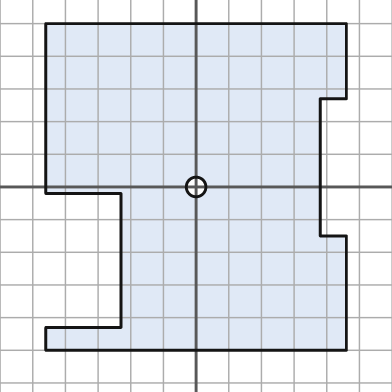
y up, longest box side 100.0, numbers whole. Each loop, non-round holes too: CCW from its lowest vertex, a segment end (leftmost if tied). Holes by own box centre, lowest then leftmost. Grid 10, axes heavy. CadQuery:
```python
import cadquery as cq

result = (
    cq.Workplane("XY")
    .moveTo(-46.0, -50.0)
    .lineTo(46.0, -50.0)
    .lineTo(46.0, -15.0)
    .lineTo(38.0, -15.0)
    .lineTo(38.0, 27.0)
    .lineTo(46.0, 27.0)
    .lineTo(46.0, 50.0)
    .lineTo(-46.0, 50.0)
    .lineTo(-46.0, -2.0)
    .lineTo(-23.0, -2.0)
    .lineTo(-23.0, -43.0)
    .lineTo(-46.0, -43.0)
    .close()
    .moveTo(0.0, 0.0)
    .circle(3.0)
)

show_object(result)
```